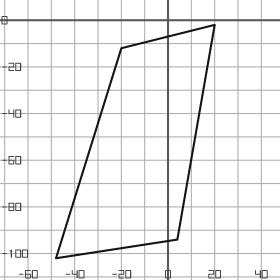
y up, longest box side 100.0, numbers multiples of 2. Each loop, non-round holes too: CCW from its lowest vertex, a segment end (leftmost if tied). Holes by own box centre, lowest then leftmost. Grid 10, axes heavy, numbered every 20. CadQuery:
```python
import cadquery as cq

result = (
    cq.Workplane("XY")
    .moveTo(-48.0, -102.0)
    .lineTo(4.0, -94.0)
    .lineTo(20.0, -2.0)
    .lineTo(-20.0, -12.0)
    .close()
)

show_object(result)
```